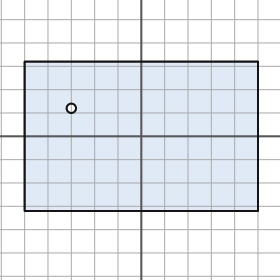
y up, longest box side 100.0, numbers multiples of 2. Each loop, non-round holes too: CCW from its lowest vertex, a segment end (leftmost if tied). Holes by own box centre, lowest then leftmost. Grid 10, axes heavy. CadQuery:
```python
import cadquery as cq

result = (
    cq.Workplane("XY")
    .moveTo(-50.0, -32.0)
    .lineTo(50.0, -32.0)
    .lineTo(50.0, 32.0)
    .lineTo(-50.0, 32.0)
    .close()
    .moveTo(-30.0, 12.0)
    .circle(2.0)
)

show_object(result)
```